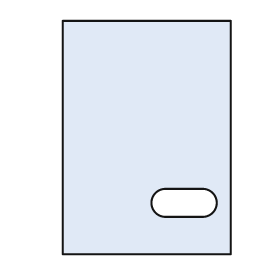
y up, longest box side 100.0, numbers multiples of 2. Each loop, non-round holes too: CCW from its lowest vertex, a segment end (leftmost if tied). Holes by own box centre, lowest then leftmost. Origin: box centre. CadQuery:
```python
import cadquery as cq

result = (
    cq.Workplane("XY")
    .moveTo(-36.0, -50.0)
    .lineTo(36.0, -50.0)
    .lineTo(36.0, 50.0)
    .lineTo(-36.0, 50.0)
    .close()
    .moveTo(8.0, -34.0)
    .lineTo(24.0, -34.0)
    .threePointArc((30.0, -28.0), (24.0, -22.0))
    .lineTo(8.0, -22.0)
    .threePointArc((2.0, -28.0), (8.0, -34.0))
    .close()
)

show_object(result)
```